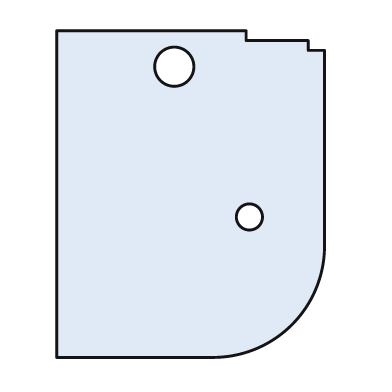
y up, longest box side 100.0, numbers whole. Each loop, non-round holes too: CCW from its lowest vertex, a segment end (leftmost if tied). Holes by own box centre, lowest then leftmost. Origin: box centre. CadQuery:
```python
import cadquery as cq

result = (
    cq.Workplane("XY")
    .moveTo(-41.0, -50.0)
    .lineTo(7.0, -50.0)
    .threePointArc((31.0, -40.0), (41.0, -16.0))
    .lineTo(41.0, 44.0)
    .lineTo(36.0, 44.0)
    .lineTo(36.0, 47.0)
    .lineTo(17.0, 47.0)
    .lineTo(17.0, 50.0)
    .lineTo(-41.0, 50.0)
    .close()
    .moveTo(18.0, -7.0)
    .circle(4.0)
    .moveTo(-5.0, 39.0)
    .circle(6.0)
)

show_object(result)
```